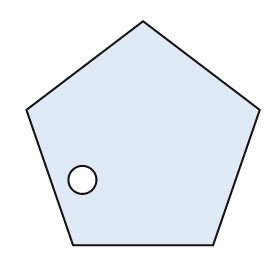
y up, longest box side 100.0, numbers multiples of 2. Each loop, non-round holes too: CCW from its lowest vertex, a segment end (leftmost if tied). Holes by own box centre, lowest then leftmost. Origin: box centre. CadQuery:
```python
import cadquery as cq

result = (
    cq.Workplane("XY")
    .moveTo(-30.0, -48.0)
    .lineTo(30.0, -48.0)
    .lineTo(50.0, 10.0)
    .lineTo(0.0, 48.0)
    .lineTo(-50.0, 10.0)
    .close()
    .moveTo(-26.0, -20.0)
    .circle(6.0)
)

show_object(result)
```